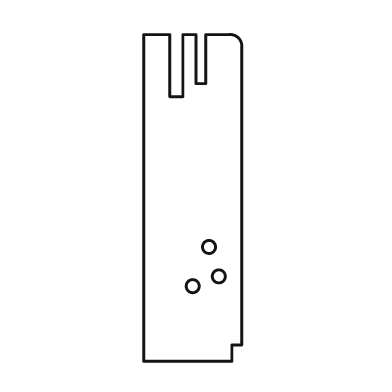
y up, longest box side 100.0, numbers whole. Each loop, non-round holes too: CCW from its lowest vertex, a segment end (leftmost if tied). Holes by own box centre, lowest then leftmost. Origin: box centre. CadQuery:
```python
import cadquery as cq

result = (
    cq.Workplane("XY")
    .moveTo(-15.0, -50.0)
    .lineTo(12.0, -50.0)
    .lineTo(12.0, -45.0)
    .lineTo(15.0, -45.0)
    .lineTo(15.0, 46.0)
    .threePointArc((14.0, 49.0), (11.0, 50.0))
    .lineTo(4.0, 50.0)
    .lineTo(4.0, 35.0)
    .lineTo(1.0, 35.0)
    .lineTo(1.0, 50.0)
    .lineTo(-3.0, 50.0)
    .lineTo(-3.0, 31.0)
    .lineTo(-7.0, 31.0)
    .lineTo(-7.0, 50.0)
    .lineTo(-15.0, 50.0)
    .close()
    .moveTo(0.0, -27.0)
    .circle(2.0)
    .moveTo(8.0, -24.0)
    .circle(2.0)
    .moveTo(5.0, -15.0)
    .circle(2.0)
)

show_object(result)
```